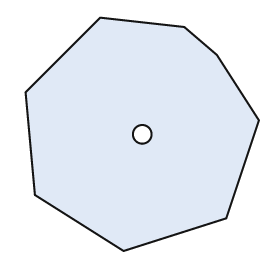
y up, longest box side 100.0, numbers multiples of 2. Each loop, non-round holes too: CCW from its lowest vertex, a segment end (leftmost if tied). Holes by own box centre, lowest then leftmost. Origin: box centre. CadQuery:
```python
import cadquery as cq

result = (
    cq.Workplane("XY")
    .moveTo(-8.0, -50.0)
    .lineTo(36.0, -36.0)
    .lineTo(50.0, 6.0)
    .lineTo(32.0, 34.0)
    .lineTo(18.0, 46.0)
    .lineTo(-18.0, 50.0)
    .lineTo(-50.0, 18.0)
    .lineTo(-46.0, -26.0)
    .close()
    .moveTo(0.0, 0.0)
    .circle(4.0)
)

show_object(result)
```